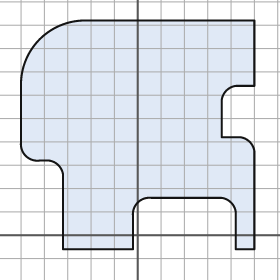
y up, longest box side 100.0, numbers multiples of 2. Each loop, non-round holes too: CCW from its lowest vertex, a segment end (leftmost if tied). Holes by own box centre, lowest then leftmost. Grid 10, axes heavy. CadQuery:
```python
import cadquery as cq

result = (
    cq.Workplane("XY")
    .moveTo(-32.0, -6.0)
    .lineTo(-2.0, -6.0)
    .lineTo(-2.0, 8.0)
    .threePointArc((0.0, 14.0), (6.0, 16.0))
    .lineTo(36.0, 16.0)
    .threePointArc((40.0, 14.0), (42.0, 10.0))
    .lineTo(42.0, -6.0)
    .lineTo(50.0, -6.0)
    .lineTo(50.0, 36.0)
    .threePointArc((48.0, 40.0), (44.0, 42.0))
    .lineTo(36.0, 42.0)
    .lineTo(36.0, 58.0)
    .threePointArc((38.0, 62.0), (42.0, 64.0))
    .lineTo(50.0, 64.0)
    .lineTo(50.0, 92.0)
    .lineTo(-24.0, 92.0)
    .threePointArc((-42.0, 84.0), (-50.0, 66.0))
    .lineTo(-50.0, 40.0)
    .threePointArc((-48.0, 34.0), (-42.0, 32.0))
    .lineTo(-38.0, 32.0)
    .threePointArc((-34.0, 30.0), (-32.0, 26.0))
    .close()
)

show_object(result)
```